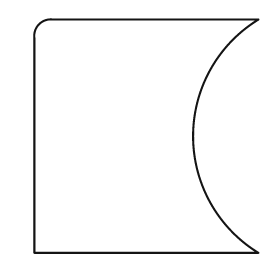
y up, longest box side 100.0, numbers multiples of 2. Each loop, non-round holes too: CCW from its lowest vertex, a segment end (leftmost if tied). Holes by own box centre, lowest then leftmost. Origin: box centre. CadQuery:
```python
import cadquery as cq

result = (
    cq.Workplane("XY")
    .moveTo(-48.0, -50.0)
    .lineTo(48.0, -50.0)
    .threePointArc((20.0, 0.0), (48.0, 50.0))
    .lineTo(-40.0, 50.0)
    .threePointArc((-46.0, 48.0), (-48.0, 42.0))
    .close()
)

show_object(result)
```